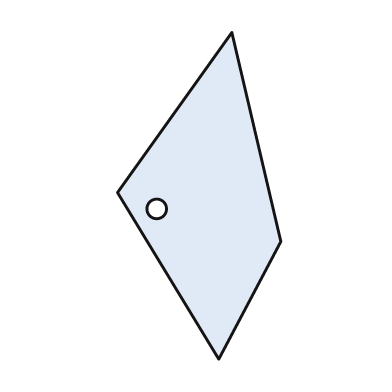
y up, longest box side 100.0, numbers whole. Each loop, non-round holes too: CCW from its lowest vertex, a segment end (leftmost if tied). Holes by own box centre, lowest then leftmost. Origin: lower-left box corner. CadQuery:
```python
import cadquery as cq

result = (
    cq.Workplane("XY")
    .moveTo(31.0, 0.0)
    .lineTo(50.0, 36.0)
    .lineTo(35.0, 100.0)
    .lineTo(0.0, 51.0)
    .close()
    .moveTo(12.0, 46.0)
    .circle(3.0)
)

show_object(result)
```